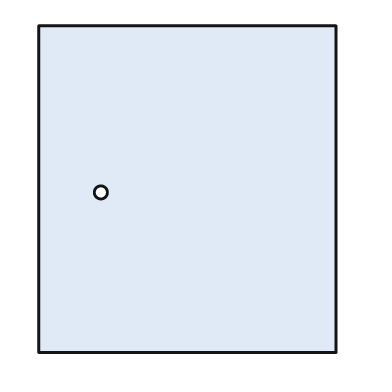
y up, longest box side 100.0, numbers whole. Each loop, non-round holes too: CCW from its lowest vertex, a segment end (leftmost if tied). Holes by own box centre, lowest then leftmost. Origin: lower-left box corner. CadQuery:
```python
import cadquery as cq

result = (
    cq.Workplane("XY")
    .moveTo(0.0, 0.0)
    .lineTo(91.0, 0.0)
    .lineTo(91.0, 100.0)
    .lineTo(0.0, 100.0)
    .close()
    .moveTo(19.0, 49.0)
    .circle(2.0)
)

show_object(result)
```